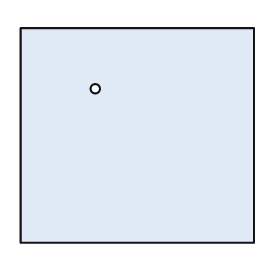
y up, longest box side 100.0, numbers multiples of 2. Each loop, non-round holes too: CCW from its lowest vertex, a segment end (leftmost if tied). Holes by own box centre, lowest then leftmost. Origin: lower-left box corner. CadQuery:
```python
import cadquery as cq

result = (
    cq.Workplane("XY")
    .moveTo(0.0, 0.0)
    .lineTo(100.0, 0.0)
    .lineTo(100.0, 92.0)
    .lineTo(0.0, 92.0)
    .close()
    .moveTo(32.0, 66.0)
    .circle(2.0)
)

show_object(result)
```